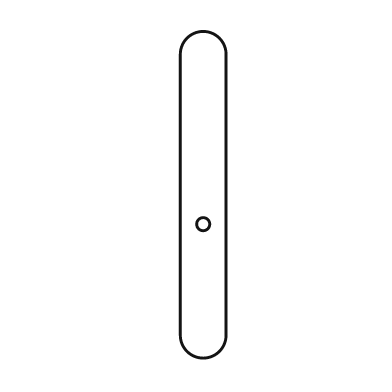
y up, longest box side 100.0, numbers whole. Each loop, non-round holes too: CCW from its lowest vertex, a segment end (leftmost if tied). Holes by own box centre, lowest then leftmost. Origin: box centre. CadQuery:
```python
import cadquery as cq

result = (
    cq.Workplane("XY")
    .moveTo(-7.0, -43.0)
    .threePointArc((0.0, -50.0), (7.0, -43.0))
    .lineTo(7.0, 43.0)
    .threePointArc((0.0, 50.0), (-7.0, 43.0))
    .close()
    .moveTo(0.0, -9.0)
    .circle(2.0)
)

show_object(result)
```